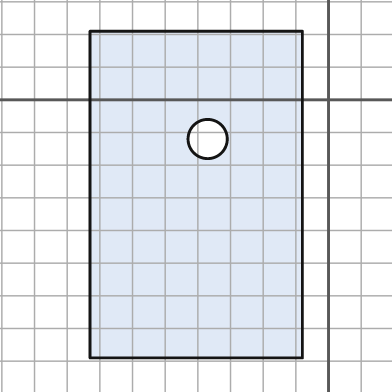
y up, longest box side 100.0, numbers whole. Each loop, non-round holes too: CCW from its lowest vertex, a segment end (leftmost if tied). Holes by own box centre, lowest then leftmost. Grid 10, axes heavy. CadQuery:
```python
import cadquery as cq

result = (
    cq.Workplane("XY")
    .moveTo(-73.0, -79.0)
    .lineTo(-8.0, -79.0)
    .lineTo(-8.0, 21.0)
    .lineTo(-73.0, 21.0)
    .close()
    .moveTo(-37.0, -12.0)
    .circle(6.0)
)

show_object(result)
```